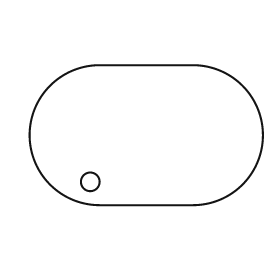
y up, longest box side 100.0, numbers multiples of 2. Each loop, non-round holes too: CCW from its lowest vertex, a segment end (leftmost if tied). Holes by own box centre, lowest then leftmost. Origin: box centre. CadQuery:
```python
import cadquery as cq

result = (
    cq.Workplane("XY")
    .moveTo(-20.0, -30.0)
    .lineTo(20.0, -30.0)
    .threePointArc((50.0, 0.0), (20.0, 30.0))
    .lineTo(-20.0, 30.0)
    .threePointArc((-50.0, 0.0), (-20.0, -30.0))
    .close()
    .moveTo(-24.0, -20.0)
    .circle(4.0)
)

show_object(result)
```